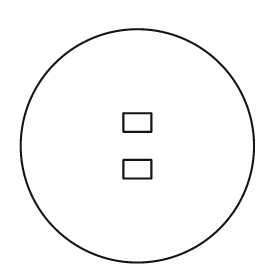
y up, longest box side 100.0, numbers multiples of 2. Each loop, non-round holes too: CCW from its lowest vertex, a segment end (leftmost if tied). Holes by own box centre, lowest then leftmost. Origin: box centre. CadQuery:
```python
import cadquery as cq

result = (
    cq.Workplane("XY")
    .moveTo(0.0, 0.0)
    .circle(50.0)
    .moveTo(-6.0, -14.0)
    .lineTo(6.0, -14.0)
    .lineTo(6.0, -6.0)
    .lineTo(-6.0, -6.0)
    .close()
    .moveTo(-6.0, 6.0)
    .lineTo(6.0, 6.0)
    .lineTo(6.0, 14.0)
    .lineTo(-6.0, 14.0)
    .close()
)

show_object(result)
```